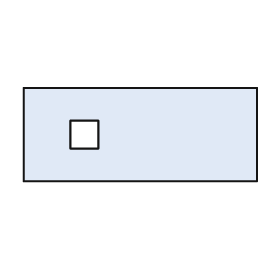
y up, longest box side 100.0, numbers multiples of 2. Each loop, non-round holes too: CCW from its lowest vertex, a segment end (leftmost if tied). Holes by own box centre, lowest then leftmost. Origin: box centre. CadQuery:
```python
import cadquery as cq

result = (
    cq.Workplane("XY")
    .moveTo(-50.0, -20.0)
    .lineTo(50.0, -20.0)
    .lineTo(50.0, 20.0)
    .lineTo(-50.0, 20.0)
    .close()
    .moveTo(-30.0, -6.0)
    .lineTo(-18.0, -6.0)
    .lineTo(-18.0, 6.0)
    .lineTo(-30.0, 6.0)
    .close()
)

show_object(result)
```